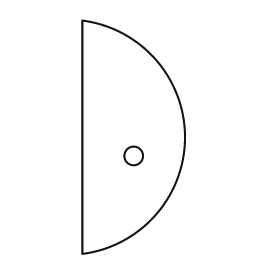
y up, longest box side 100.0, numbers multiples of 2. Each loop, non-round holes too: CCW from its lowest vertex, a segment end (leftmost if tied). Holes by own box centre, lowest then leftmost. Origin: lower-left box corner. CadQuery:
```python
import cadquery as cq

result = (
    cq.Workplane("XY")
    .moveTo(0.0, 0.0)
    .threePointArc((44.0, 50.0), (0.0, 100.0))
    .close()
    .moveTo(22.0, 42.0)
    .circle(4.0)
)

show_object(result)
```